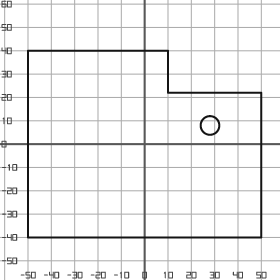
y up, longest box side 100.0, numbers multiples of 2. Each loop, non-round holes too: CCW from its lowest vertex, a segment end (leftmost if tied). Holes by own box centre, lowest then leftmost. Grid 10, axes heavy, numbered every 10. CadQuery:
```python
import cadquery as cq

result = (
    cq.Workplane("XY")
    .moveTo(-50.0, -40.0)
    .lineTo(50.0, -40.0)
    .lineTo(50.0, 22.0)
    .lineTo(10.0, 22.0)
    .lineTo(10.0, 40.0)
    .lineTo(-50.0, 40.0)
    .close()
    .moveTo(28.0, 8.0)
    .circle(4.0)
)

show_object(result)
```